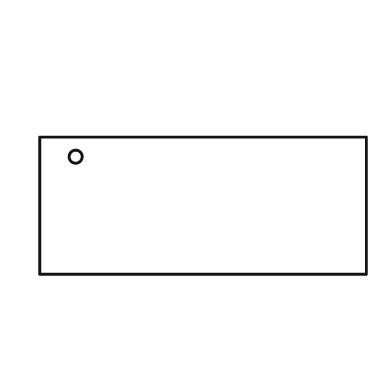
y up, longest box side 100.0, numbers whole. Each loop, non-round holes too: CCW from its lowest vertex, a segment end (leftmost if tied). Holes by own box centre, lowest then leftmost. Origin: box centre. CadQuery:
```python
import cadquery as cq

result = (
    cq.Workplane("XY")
    .moveTo(-50.0, -21.0)
    .lineTo(50.0, -21.0)
    .lineTo(50.0, 21.0)
    .lineTo(-50.0, 21.0)
    .close()
    .moveTo(-39.0, 15.0)
    .circle(2.0)
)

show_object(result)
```